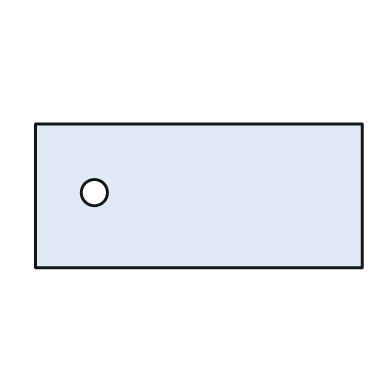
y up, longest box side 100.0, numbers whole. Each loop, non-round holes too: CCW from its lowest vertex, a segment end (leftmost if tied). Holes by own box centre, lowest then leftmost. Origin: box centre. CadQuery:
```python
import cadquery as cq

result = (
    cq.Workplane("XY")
    .moveTo(-50.0, -22.0)
    .lineTo(50.0, -22.0)
    .lineTo(50.0, 22.0)
    .lineTo(-50.0, 22.0)
    .close()
    .moveTo(-32.0, 1.0)
    .circle(4.0)
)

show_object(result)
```